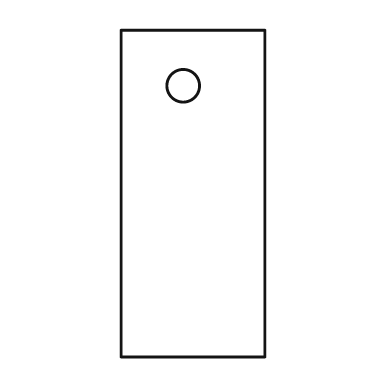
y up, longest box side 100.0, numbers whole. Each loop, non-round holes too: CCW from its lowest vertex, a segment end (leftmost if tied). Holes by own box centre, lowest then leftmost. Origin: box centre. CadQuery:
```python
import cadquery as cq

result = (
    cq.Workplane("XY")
    .moveTo(-22.0, -50.0)
    .lineTo(22.0, -50.0)
    .lineTo(22.0, 50.0)
    .lineTo(-22.0, 50.0)
    .close()
    .moveTo(-3.0, 33.0)
    .circle(5.0)
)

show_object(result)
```